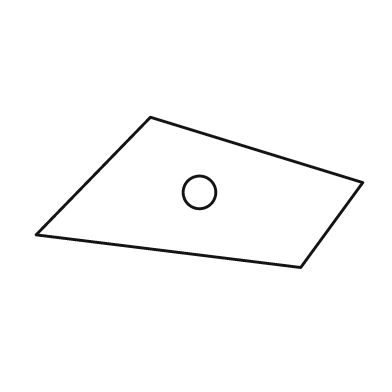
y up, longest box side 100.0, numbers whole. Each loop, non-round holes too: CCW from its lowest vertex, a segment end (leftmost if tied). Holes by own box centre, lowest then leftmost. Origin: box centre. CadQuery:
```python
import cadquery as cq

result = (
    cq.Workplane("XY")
    .moveTo(31.0, -23.0)
    .lineTo(50.0, 3.0)
    .lineTo(-15.0, 23.0)
    .lineTo(-50.0, -13.0)
    .close()
    .moveTo(0.0, 0.0)
    .circle(5.0)
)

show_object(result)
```